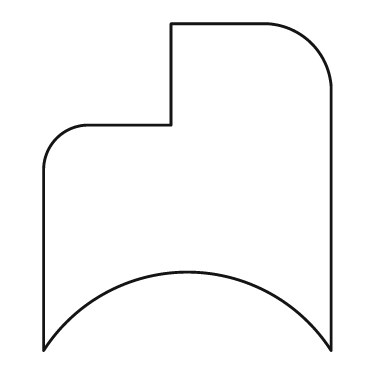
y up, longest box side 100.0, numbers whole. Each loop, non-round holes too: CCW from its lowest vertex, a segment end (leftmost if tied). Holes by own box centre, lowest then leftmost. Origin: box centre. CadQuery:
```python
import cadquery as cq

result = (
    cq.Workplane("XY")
    .moveTo(-44.0, -50.0)
    .threePointArc((0.0, -26.0), (44.0, -50.0))
    .lineTo(44.0, 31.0)
    .threePointArc((38.0, 44.0), (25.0, 50.0))
    .lineTo(-5.0, 50.0)
    .lineTo(-5.0, 19.0)
    .lineTo(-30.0, 19.0)
    .threePointArc((-40.0, 15.0), (-44.0, 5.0))
    .close()
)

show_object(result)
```